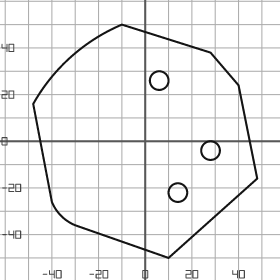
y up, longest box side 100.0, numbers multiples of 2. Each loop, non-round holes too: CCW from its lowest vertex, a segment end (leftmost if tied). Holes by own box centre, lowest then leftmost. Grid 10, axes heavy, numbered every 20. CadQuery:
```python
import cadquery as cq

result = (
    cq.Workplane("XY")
    .moveTo(10.0, -50.0)
    .lineTo(48.0, -16.0)
    .lineTo(40.0, 24.0)
    .lineTo(28.0, 38.0)
    .lineTo(-10.0, 50.0)
    .threePointArc((-32.0, 36.0), (-48.0, 16.0))
    .lineTo(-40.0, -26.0)
    .threePointArc((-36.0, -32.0), (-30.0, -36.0))
    .close()
    .moveTo(14.0, -22.0)
    .circle(4.0)
    .moveTo(28.0, -4.0)
    .circle(4.0)
    .moveTo(6.0, 26.0)
    .circle(4.0)
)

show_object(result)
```